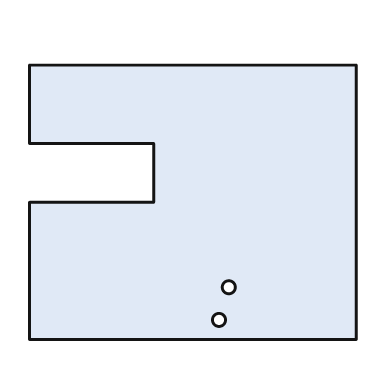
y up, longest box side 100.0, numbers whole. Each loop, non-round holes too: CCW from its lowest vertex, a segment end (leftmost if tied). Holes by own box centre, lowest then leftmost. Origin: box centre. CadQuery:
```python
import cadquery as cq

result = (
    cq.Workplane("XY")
    .moveTo(-50.0, -42.0)
    .lineTo(50.0, -42.0)
    .lineTo(50.0, 42.0)
    .lineTo(-50.0, 42.0)
    .lineTo(-50.0, 18.0)
    .lineTo(-12.0, 18.0)
    .lineTo(-12.0, 0.0)
    .lineTo(-50.0, 0.0)
    .close()
    .moveTo(8.0, -36.0)
    .circle(2.0)
    .moveTo(11.0, -26.0)
    .circle(2.0)
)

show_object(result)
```